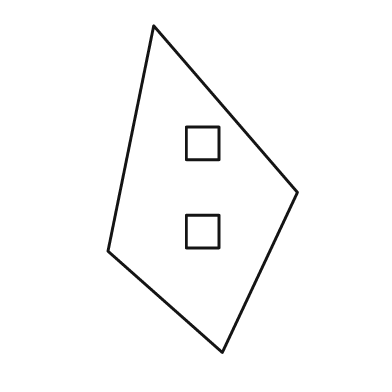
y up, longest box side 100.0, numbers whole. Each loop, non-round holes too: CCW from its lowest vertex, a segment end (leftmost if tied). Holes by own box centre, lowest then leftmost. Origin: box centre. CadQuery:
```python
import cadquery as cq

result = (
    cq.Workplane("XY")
    .moveTo(6.0, -50.0)
    .lineTo(29.0, -1.0)
    .lineTo(-15.0, 50.0)
    .lineTo(-29.0, -19.0)
    .close()
    .moveTo(-5.0, -18.0)
    .lineTo(5.0, -18.0)
    .lineTo(5.0, -8.0)
    .lineTo(-5.0, -8.0)
    .close()
    .moveTo(-5.0, 9.0)
    .lineTo(5.0, 9.0)
    .lineTo(5.0, 19.0)
    .lineTo(-5.0, 19.0)
    .close()
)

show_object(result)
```